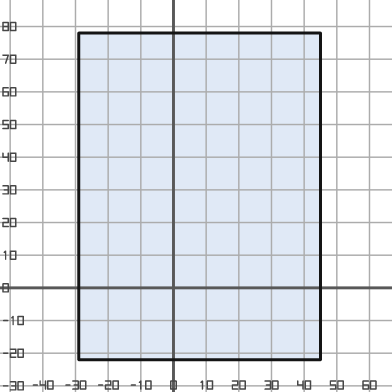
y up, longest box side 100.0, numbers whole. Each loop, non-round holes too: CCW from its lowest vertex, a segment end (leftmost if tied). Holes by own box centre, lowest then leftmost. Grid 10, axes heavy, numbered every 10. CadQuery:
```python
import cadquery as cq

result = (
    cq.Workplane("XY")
    .moveTo(-29.0, -22.0)
    .lineTo(45.0, -22.0)
    .lineTo(45.0, 78.0)
    .lineTo(-29.0, 78.0)
    .close()
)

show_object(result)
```